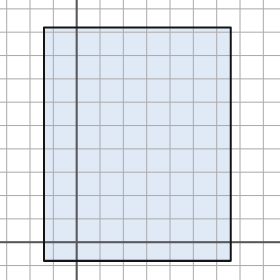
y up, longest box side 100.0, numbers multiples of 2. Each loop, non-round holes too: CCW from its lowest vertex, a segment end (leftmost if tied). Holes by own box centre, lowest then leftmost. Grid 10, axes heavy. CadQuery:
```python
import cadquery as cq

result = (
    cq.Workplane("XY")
    .moveTo(-14.0, -8.0)
    .lineTo(66.0, -8.0)
    .lineTo(66.0, 92.0)
    .lineTo(-14.0, 92.0)
    .close()
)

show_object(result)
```